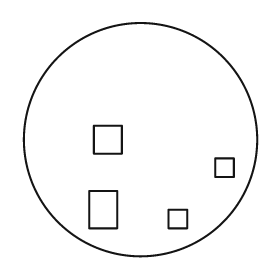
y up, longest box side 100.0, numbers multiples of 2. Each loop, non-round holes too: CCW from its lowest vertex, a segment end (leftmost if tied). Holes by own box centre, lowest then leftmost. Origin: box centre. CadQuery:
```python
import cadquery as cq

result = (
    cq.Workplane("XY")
    .moveTo(0.0, 0.0)
    .circle(50.0)
    .moveTo(12.0, -38.0)
    .lineTo(20.0, -38.0)
    .lineTo(20.0, -30.0)
    .lineTo(12.0, -30.0)
    .close()
    .moveTo(-22.0, -38.0)
    .lineTo(-10.0, -38.0)
    .lineTo(-10.0, -22.0)
    .lineTo(-22.0, -22.0)
    .close()
    .moveTo(32.0, -16.0)
    .lineTo(40.0, -16.0)
    .lineTo(40.0, -8.0)
    .lineTo(32.0, -8.0)
    .close()
    .moveTo(-20.0, -6.0)
    .lineTo(-8.0, -6.0)
    .lineTo(-8.0, 6.0)
    .lineTo(-20.0, 6.0)
    .close()
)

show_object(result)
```